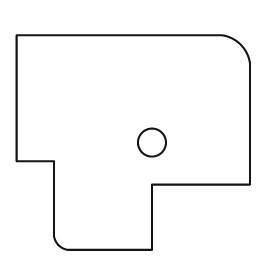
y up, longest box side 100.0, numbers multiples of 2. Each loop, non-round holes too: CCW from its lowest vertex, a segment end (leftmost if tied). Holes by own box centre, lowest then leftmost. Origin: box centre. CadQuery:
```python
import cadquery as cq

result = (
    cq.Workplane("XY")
    .moveTo(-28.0, -46.0)
    .lineTo(8.0, -46.0)
    .lineTo(8.0, -18.0)
    .lineTo(50.0, -18.0)
    .lineTo(50.0, 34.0)
    .threePointArc((46.0, 42.0), (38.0, 46.0))
    .lineTo(-50.0, 46.0)
    .lineTo(-50.0, -8.0)
    .lineTo(-34.0, -8.0)
    .lineTo(-34.0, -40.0)
    .threePointArc((-32.0, -44.0), (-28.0, -46.0))
    .close()
    .moveTo(8.0, 0.0)
    .circle(6.0)
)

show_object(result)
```